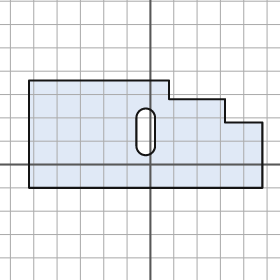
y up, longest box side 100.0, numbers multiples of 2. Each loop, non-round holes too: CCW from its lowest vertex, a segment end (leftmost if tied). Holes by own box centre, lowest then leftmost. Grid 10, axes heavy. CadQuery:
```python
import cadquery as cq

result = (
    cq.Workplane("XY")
    .moveTo(-52.0, -10.0)
    .lineTo(48.0, -10.0)
    .lineTo(48.0, 18.0)
    .lineTo(32.0, 18.0)
    .lineTo(32.0, 28.0)
    .lineTo(8.0, 28.0)
    .lineTo(8.0, 36.0)
    .lineTo(-52.0, 36.0)
    .close()
    .moveTo(-6.0, 8.0)
    .threePointArc((-2.0, 4.0), (2.0, 8.0))
    .lineTo(2.0, 20.0)
    .threePointArc((-2.0, 24.0), (-6.0, 20.0))
    .close()
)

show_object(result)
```